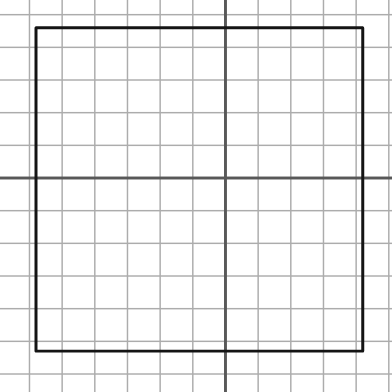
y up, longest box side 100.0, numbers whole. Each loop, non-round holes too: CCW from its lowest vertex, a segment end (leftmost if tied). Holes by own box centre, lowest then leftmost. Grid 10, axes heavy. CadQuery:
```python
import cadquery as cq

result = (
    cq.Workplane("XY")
    .moveTo(-58.0, -53.0)
    .lineTo(42.0, -53.0)
    .lineTo(42.0, 46.0)
    .lineTo(-58.0, 46.0)
    .close()
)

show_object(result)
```